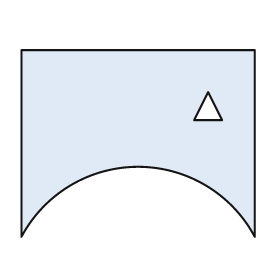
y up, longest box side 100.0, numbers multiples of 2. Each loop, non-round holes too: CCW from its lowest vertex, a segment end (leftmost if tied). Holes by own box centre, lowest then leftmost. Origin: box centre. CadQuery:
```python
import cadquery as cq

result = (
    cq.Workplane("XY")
    .moveTo(-50.0, -40.0)
    .threePointArc((0.0, -10.0), (50.0, -40.0))
    .lineTo(50.0, 40.0)
    .lineTo(-50.0, 40.0)
    .close()
    .moveTo(24.0, 10.0)
    .lineTo(36.0, 10.0)
    .lineTo(30.0, 22.0)
    .close()
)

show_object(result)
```